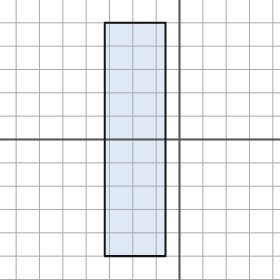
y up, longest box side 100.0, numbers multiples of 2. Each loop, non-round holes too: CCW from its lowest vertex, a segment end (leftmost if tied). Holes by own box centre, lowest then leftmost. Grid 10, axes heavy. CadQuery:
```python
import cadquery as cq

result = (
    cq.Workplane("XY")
    .moveTo(-32.0, -50.0)
    .lineTo(-6.0, -50.0)
    .lineTo(-6.0, 50.0)
    .lineTo(-32.0, 50.0)
    .close()
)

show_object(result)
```